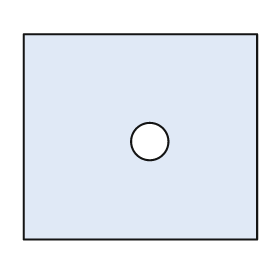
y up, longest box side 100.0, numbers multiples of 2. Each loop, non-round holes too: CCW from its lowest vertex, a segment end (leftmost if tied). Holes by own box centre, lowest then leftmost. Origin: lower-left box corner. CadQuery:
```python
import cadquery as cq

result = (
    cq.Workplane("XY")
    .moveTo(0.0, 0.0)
    .lineTo(100.0, 0.0)
    .lineTo(100.0, 88.0)
    .lineTo(0.0, 88.0)
    .close()
    .moveTo(54.0, 42.0)
    .circle(8.0)
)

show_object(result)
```